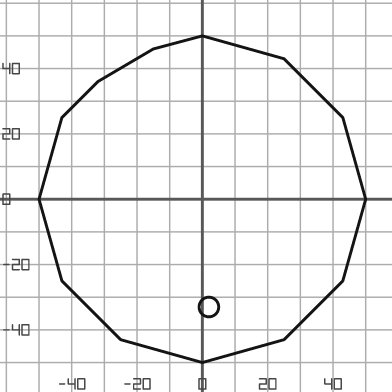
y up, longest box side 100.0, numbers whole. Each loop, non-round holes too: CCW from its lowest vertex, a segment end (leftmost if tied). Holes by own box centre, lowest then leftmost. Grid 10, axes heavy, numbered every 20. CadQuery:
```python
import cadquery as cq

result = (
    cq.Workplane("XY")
    .moveTo(0.0, -50.0)
    .lineTo(25.0, -43.0)
    .lineTo(43.0, -25.0)
    .lineTo(50.0, 0.0)
    .lineTo(43.0, 25.0)
    .lineTo(25.0, 43.0)
    .lineTo(0.0, 50.0)
    .lineTo(-15.0, 46.0)
    .lineTo(-32.0, 36.0)
    .lineTo(-43.0, 25.0)
    .lineTo(-50.0, 0.0)
    .lineTo(-43.0, -25.0)
    .lineTo(-25.0, -43.0)
    .close()
    .moveTo(2.0, -33.0)
    .circle(3.0)
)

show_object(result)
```